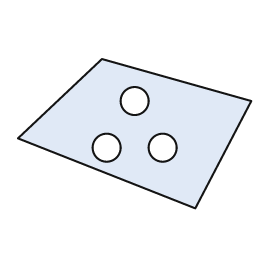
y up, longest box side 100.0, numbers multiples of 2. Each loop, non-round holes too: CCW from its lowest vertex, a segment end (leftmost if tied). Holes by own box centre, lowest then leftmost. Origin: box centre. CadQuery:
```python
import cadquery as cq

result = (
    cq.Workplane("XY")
    .moveTo(26.0, -32.0)
    .lineTo(50.0, 14.0)
    .lineTo(-14.0, 32.0)
    .lineTo(-50.0, -2.0)
    .close()
    .moveTo(-12.0, -6.0)
    .circle(6.0)
    .moveTo(12.0, -6.0)
    .circle(6.0)
    .moveTo(0.0, 14.0)
    .circle(6.0)
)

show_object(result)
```